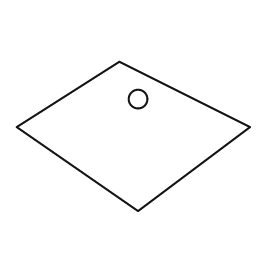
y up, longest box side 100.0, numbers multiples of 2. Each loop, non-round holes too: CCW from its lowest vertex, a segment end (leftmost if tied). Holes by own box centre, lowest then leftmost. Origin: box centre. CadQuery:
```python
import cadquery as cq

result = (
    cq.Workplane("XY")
    .moveTo(2.0, -32.0)
    .lineTo(50.0, 4.0)
    .lineTo(-6.0, 32.0)
    .lineTo(-50.0, 4.0)
    .close()
    .moveTo(2.0, 16.0)
    .circle(4.0)
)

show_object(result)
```